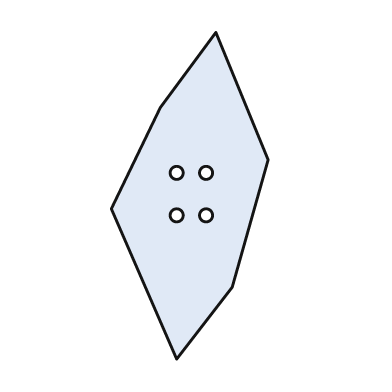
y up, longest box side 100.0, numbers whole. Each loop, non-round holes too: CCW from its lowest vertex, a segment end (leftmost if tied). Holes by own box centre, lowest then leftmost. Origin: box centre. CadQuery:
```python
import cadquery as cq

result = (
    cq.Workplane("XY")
    .moveTo(-4.0, -50.0)
    .lineTo(13.0, -28.0)
    .lineTo(24.0, 11.0)
    .lineTo(8.0, 50.0)
    .lineTo(-9.0, 27.0)
    .lineTo(-24.0, -4.0)
    .close()
    .moveTo(-4.0, -6.0)
    .circle(2.0)
    .moveTo(5.0, -6.0)
    .circle(2.0)
    .moveTo(-4.0, 7.0)
    .circle(2.0)
    .moveTo(5.0, 7.0)
    .circle(2.0)
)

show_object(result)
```